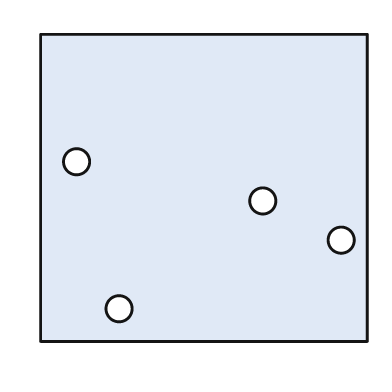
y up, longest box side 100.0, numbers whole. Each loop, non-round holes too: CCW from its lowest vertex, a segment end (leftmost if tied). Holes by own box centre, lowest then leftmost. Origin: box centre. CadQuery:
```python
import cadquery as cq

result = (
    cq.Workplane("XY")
    .moveTo(-50.0, -47.0)
    .lineTo(50.0, -47.0)
    .lineTo(50.0, 47.0)
    .lineTo(-50.0, 47.0)
    .close()
    .moveTo(-26.0, -37.0)
    .circle(4.0)
    .moveTo(42.0, -16.0)
    .circle(4.0)
    .moveTo(18.0, -4.0)
    .circle(4.0)
    .moveTo(-39.0, 8.0)
    .circle(4.0)
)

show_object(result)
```